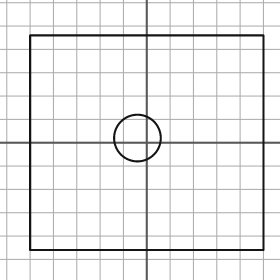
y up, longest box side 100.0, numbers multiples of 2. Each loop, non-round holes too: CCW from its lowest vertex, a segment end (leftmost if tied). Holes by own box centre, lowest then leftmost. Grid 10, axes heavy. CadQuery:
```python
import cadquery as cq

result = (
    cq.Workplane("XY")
    .moveTo(-50.0, -46.0)
    .lineTo(50.0, -46.0)
    .lineTo(50.0, 46.0)
    .lineTo(-50.0, 46.0)
    .close()
    .moveTo(-4.0, 2.0)
    .circle(10.0)
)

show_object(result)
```